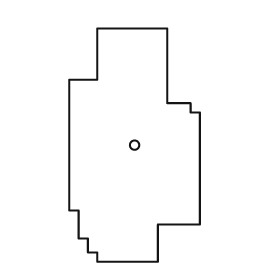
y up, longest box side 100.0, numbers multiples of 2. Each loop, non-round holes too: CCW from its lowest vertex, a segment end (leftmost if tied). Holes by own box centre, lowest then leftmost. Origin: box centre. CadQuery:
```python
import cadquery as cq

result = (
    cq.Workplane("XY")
    .moveTo(-16.0, -50.0)
    .lineTo(10.0, -50.0)
    .lineTo(10.0, -34.0)
    .lineTo(28.0, -34.0)
    .lineTo(28.0, 14.0)
    .lineTo(24.0, 14.0)
    .lineTo(24.0, 18.0)
    .lineTo(14.0, 18.0)
    .lineTo(14.0, 50.0)
    .lineTo(-16.0, 50.0)
    .lineTo(-16.0, 28.0)
    .lineTo(-28.0, 28.0)
    .lineTo(-28.0, -28.0)
    .lineTo(-24.0, -28.0)
    .lineTo(-24.0, -40.0)
    .lineTo(-20.0, -40.0)
    .lineTo(-20.0, -46.0)
    .lineTo(-16.0, -46.0)
    .close()
    .moveTo(0.0, 0.0)
    .circle(2.0)
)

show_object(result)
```